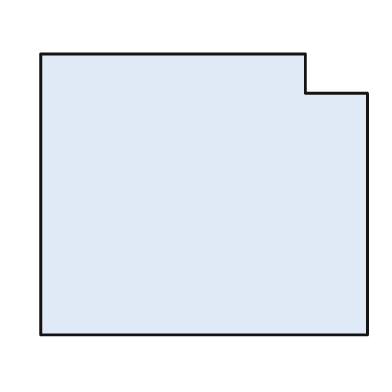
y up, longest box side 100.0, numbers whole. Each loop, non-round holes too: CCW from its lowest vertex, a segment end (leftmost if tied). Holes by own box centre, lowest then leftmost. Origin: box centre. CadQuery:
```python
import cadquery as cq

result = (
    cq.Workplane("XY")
    .moveTo(-50.0, -43.0)
    .lineTo(50.0, -43.0)
    .lineTo(50.0, 31.0)
    .lineTo(31.0, 31.0)
    .lineTo(31.0, 43.0)
    .lineTo(-50.0, 43.0)
    .close()
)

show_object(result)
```